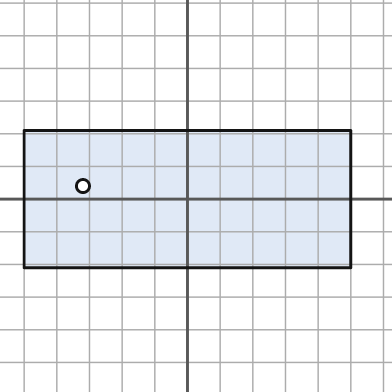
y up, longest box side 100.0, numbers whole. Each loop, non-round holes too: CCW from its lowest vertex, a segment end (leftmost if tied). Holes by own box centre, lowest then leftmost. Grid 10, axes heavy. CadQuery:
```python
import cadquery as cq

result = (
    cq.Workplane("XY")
    .moveTo(-50.0, -21.0)
    .lineTo(50.0, -21.0)
    .lineTo(50.0, 21.0)
    .lineTo(-50.0, 21.0)
    .close()
    .moveTo(-32.0, 4.0)
    .circle(2.0)
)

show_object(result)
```